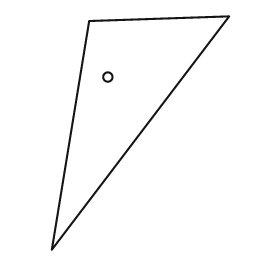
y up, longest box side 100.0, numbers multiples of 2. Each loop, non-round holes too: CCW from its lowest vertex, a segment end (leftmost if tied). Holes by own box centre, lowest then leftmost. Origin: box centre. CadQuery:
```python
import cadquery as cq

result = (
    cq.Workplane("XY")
    .moveTo(-38.0, -50.0)
    .lineTo(38.0, 50.0)
    .lineTo(-22.0, 48.0)
    .close()
    .moveTo(-14.0, 24.0)
    .circle(2.0)
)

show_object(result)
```